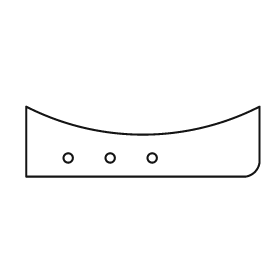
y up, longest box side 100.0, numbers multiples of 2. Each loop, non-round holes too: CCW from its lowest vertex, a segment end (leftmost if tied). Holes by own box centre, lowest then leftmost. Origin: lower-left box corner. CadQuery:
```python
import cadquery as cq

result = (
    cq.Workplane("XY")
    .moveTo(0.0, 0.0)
    .lineTo(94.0, 0.0)
    .threePointArc((98.0, 2.0), (100.0, 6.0))
    .lineTo(100.0, 30.0)
    .threePointArc((50.0, 18.0), (0.0, 30.0))
    .close()
    .moveTo(18.0, 8.0)
    .circle(2.0)
    .moveTo(36.0, 8.0)
    .circle(2.0)
    .moveTo(54.0, 8.0)
    .circle(2.0)
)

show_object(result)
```